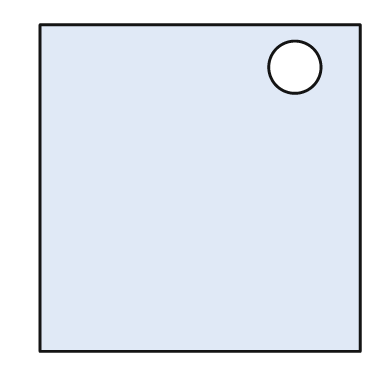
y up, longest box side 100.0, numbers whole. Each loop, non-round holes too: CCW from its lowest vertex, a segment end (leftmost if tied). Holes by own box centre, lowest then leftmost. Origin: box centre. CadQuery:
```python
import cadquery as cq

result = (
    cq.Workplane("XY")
    .moveTo(-49.0, -50.0)
    .lineTo(49.0, -50.0)
    .lineTo(49.0, 50.0)
    .lineTo(-49.0, 50.0)
    .close()
    .moveTo(29.0, 37.0)
    .circle(8.0)
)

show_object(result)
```